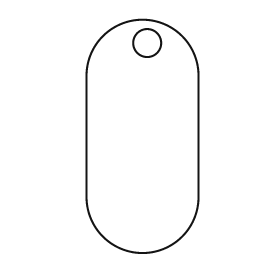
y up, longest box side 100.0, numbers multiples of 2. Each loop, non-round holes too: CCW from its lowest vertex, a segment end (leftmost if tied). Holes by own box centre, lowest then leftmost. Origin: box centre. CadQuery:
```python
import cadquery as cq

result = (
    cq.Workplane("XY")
    .moveTo(-24.0, -26.0)
    .threePointArc((0.0, -50.0), (24.0, -26.0))
    .lineTo(24.0, 26.0)
    .threePointArc((0.0, 50.0), (-24.0, 26.0))
    .close()
    .moveTo(2.0, 40.0)
    .circle(6.0)
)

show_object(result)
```